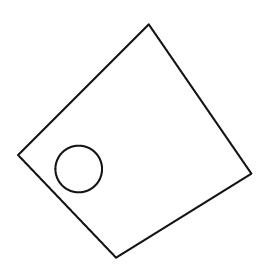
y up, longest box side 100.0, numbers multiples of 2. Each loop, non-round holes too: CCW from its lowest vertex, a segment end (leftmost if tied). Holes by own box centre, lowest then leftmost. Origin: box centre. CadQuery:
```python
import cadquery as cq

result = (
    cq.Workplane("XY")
    .moveTo(-8.0, -50.0)
    .lineTo(50.0, -14.0)
    .lineTo(6.0, 50.0)
    .lineTo(-50.0, -6.0)
    .close()
    .moveTo(-24.0, -12.0)
    .circle(10.0)
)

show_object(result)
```